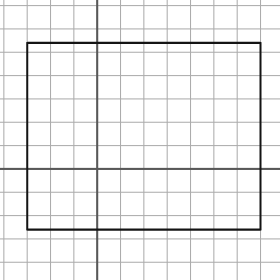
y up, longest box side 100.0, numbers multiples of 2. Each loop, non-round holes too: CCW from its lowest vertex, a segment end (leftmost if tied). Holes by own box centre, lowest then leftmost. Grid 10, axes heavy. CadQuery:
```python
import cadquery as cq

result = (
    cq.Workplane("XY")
    .moveTo(-30.0, -26.0)
    .lineTo(70.0, -26.0)
    .lineTo(70.0, 54.0)
    .lineTo(-30.0, 54.0)
    .close()
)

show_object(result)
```